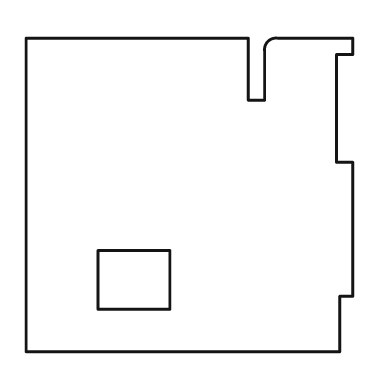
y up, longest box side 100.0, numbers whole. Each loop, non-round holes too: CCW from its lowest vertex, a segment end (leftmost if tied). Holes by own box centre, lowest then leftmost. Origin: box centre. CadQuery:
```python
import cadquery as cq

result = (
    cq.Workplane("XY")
    .moveTo(-50.0, -48.0)
    .lineTo(46.0, -48.0)
    .lineTo(46.0, -31.0)
    .lineTo(50.0, -31.0)
    .lineTo(50.0, 10.0)
    .lineTo(45.0, 10.0)
    .lineTo(45.0, 43.0)
    .lineTo(50.0, 43.0)
    .lineTo(50.0, 48.0)
    .lineTo(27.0, 48.0)
    .threePointArc((24.0, 47.0), (23.0, 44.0))
    .lineTo(23.0, 29.0)
    .lineTo(18.0, 29.0)
    .lineTo(18.0, 48.0)
    .lineTo(-50.0, 48.0)
    .close()
    .moveTo(-28.0, -35.0)
    .lineTo(-6.0, -35.0)
    .lineTo(-6.0, -17.0)
    .lineTo(-28.0, -17.0)
    .close()
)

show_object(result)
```